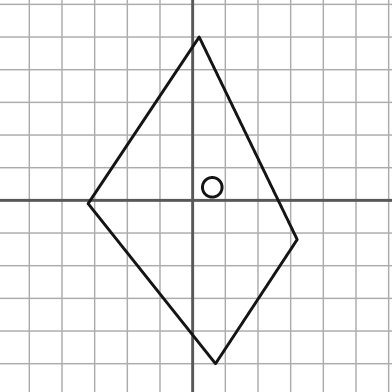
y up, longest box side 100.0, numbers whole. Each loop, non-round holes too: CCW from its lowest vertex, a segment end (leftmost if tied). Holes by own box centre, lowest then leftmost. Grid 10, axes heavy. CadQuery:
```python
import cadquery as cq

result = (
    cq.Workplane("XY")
    .moveTo(7.0, -50.0)
    .lineTo(32.0, -12.0)
    .lineTo(2.0, 50.0)
    .lineTo(-32.0, -1.0)
    .close()
    .moveTo(6.0, 4.0)
    .circle(3.0)
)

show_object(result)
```